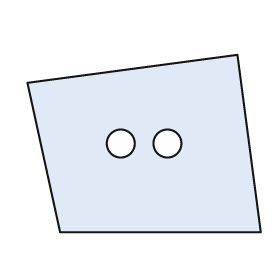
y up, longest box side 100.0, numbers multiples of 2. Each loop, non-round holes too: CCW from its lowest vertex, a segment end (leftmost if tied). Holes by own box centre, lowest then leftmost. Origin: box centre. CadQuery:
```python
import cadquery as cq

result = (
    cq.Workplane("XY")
    .moveTo(-36.0, -38.0)
    .lineTo(50.0, -38.0)
    .lineTo(40.0, 38.0)
    .lineTo(-50.0, 26.0)
    .close()
    .moveTo(-10.0, 0.0)
    .circle(6.0)
    .moveTo(10.0, 0.0)
    .circle(6.0)
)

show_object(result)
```